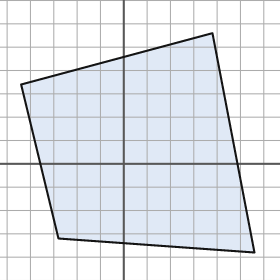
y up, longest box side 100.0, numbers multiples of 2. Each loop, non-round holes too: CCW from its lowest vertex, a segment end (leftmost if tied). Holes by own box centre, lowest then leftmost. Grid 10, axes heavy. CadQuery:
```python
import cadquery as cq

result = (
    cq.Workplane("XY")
    .moveTo(56.0, -38.0)
    .lineTo(38.0, 56.0)
    .lineTo(-44.0, 34.0)
    .lineTo(-28.0, -32.0)
    .close()
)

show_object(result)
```